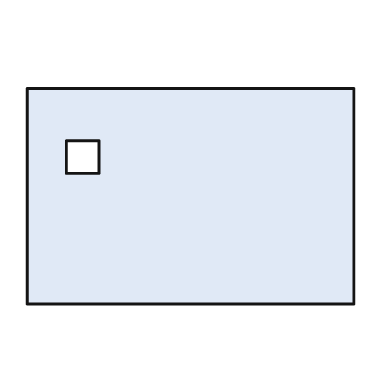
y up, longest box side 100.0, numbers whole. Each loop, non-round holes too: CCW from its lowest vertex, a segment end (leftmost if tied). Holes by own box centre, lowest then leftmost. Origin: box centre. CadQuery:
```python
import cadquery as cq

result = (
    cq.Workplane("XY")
    .moveTo(-50.0, -33.0)
    .lineTo(50.0, -33.0)
    .lineTo(50.0, 33.0)
    .lineTo(-50.0, 33.0)
    .close()
    .moveTo(-38.0, 7.0)
    .lineTo(-28.0, 7.0)
    .lineTo(-28.0, 17.0)
    .lineTo(-38.0, 17.0)
    .close()
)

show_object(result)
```